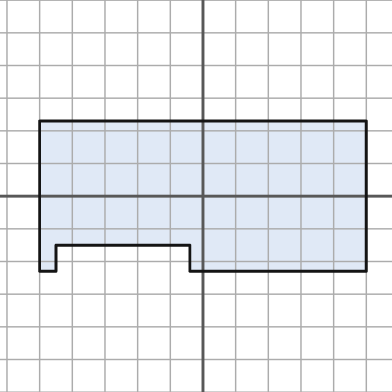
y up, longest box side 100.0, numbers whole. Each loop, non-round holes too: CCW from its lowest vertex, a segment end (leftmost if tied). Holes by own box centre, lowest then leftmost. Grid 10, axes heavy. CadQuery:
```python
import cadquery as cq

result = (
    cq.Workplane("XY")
    .moveTo(-50.0, -23.0)
    .lineTo(-45.0, -23.0)
    .lineTo(-45.0, -15.0)
    .lineTo(-4.0, -15.0)
    .lineTo(-4.0, -23.0)
    .lineTo(50.0, -23.0)
    .lineTo(50.0, 23.0)
    .lineTo(-50.0, 23.0)
    .close()
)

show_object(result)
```